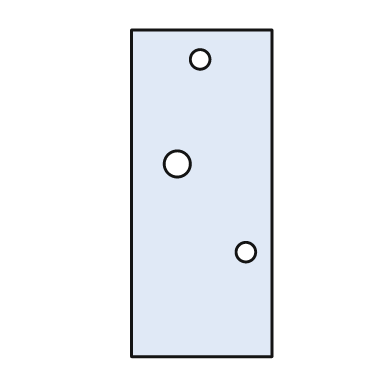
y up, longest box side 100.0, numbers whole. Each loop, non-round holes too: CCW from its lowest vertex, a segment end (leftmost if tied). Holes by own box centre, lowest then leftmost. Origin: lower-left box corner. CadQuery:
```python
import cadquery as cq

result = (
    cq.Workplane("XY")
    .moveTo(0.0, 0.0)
    .lineTo(43.0, 0.0)
    .lineTo(43.0, 100.0)
    .lineTo(0.0, 100.0)
    .close()
    .moveTo(35.0, 32.0)
    .circle(3.0)
    .moveTo(14.0, 59.0)
    .circle(4.0)
    .moveTo(21.0, 91.0)
    .circle(3.0)
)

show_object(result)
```